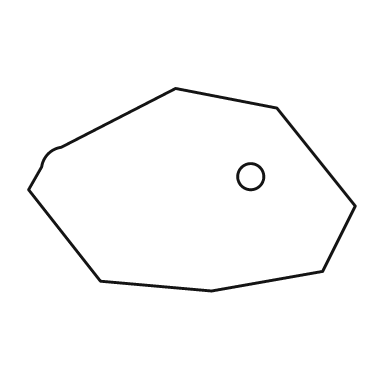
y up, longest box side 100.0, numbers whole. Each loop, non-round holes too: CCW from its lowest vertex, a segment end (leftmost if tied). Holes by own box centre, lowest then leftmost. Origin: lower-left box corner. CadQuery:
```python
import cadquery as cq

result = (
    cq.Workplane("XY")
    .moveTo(56.0, 0.0)
    .lineTo(90.0, 6.0)
    .lineTo(100.0, 26.0)
    .lineTo(76.0, 56.0)
    .lineTo(45.0, 62.0)
    .lineTo(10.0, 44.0)
    .threePointArc((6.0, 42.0), (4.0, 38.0))
    .lineTo(0.0, 31.0)
    .lineTo(22.0, 3.0)
    .close()
    .moveTo(68.0, 35.0)
    .circle(4.0)
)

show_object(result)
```